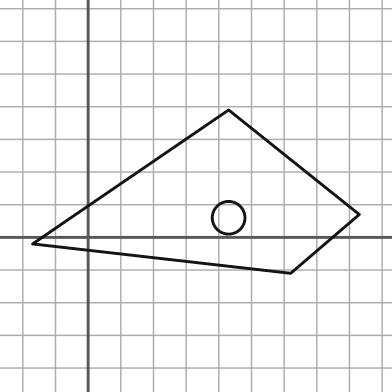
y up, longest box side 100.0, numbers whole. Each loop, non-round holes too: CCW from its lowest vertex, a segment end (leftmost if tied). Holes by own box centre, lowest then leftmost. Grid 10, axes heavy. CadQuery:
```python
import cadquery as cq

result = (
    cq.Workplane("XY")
    .moveTo(62.0, -11.0)
    .lineTo(83.0, 7.0)
    .lineTo(43.0, 39.0)
    .lineTo(-17.0, -2.0)
    .close()
    .moveTo(43.0, 6.0)
    .circle(5.0)
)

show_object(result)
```